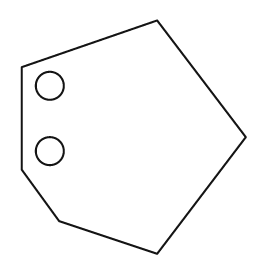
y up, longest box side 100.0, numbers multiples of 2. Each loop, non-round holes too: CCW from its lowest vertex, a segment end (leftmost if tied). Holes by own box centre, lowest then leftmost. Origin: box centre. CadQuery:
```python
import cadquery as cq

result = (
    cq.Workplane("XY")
    .moveTo(10.0, -50.0)
    .lineTo(48.0, 0.0)
    .lineTo(10.0, 50.0)
    .lineTo(-48.0, 30.0)
    .lineTo(-48.0, -14.0)
    .lineTo(-32.0, -36.0)
    .close()
    .moveTo(-36.0, -6.0)
    .circle(6.0)
    .moveTo(-36.0, 22.0)
    .circle(6.0)
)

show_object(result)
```